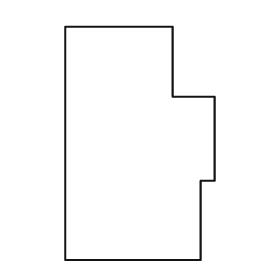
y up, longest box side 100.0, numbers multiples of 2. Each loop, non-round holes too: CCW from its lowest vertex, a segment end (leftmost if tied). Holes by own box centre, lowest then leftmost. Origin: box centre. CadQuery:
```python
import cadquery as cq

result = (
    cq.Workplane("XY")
    .moveTo(-32.0, -50.0)
    .lineTo(26.0, -50.0)
    .lineTo(26.0, -16.0)
    .lineTo(32.0, -16.0)
    .lineTo(32.0, 20.0)
    .lineTo(14.0, 20.0)
    .lineTo(14.0, 50.0)
    .lineTo(-32.0, 50.0)
    .close()
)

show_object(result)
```